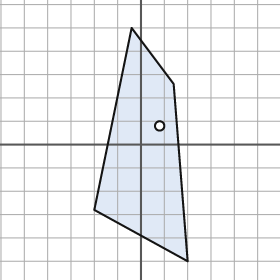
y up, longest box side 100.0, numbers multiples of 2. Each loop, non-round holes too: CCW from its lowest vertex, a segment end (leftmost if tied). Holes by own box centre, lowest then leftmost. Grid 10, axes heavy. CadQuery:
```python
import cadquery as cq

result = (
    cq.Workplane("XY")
    .moveTo(20.0, -50.0)
    .lineTo(14.0, 26.0)
    .lineTo(-4.0, 50.0)
    .lineTo(-20.0, -28.0)
    .close()
    .moveTo(8.0, 8.0)
    .circle(2.0)
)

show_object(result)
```